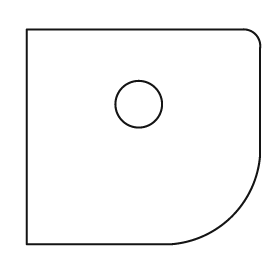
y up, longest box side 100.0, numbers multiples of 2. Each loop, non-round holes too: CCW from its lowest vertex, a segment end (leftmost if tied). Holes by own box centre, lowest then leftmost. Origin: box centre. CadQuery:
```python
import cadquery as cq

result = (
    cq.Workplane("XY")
    .moveTo(-50.0, -46.0)
    .lineTo(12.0, -46.0)
    .threePointArc((38.0, -34.0), (50.0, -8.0))
    .lineTo(50.0, 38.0)
    .threePointArc((48.0, 44.0), (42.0, 46.0))
    .lineTo(-50.0, 46.0)
    .close()
    .moveTo(-2.0, 14.0)
    .circle(10.0)
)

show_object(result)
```